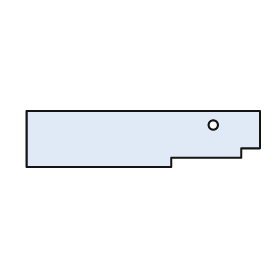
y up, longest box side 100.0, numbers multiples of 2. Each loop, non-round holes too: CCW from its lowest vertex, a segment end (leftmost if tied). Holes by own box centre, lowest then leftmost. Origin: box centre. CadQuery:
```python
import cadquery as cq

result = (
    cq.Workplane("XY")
    .moveTo(-50.0, -12.0)
    .lineTo(12.0, -12.0)
    .lineTo(12.0, -8.0)
    .lineTo(42.0, -8.0)
    .lineTo(42.0, -4.0)
    .lineTo(50.0, -4.0)
    .lineTo(50.0, 12.0)
    .lineTo(-50.0, 12.0)
    .close()
    .moveTo(30.0, 6.0)
    .circle(2.0)
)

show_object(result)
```